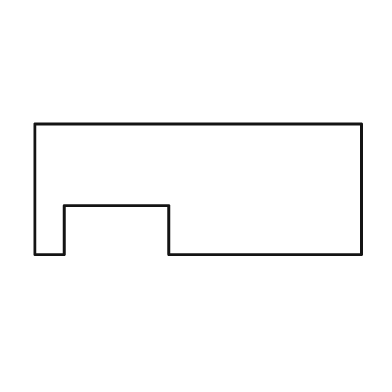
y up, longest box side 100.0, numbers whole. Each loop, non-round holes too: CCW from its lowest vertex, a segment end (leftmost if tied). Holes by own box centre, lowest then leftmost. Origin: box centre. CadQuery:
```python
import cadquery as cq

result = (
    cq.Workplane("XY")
    .moveTo(-50.0, -20.0)
    .lineTo(-41.0, -20.0)
    .lineTo(-41.0, -5.0)
    .lineTo(-9.0, -5.0)
    .lineTo(-9.0, -20.0)
    .lineTo(50.0, -20.0)
    .lineTo(50.0, 20.0)
    .lineTo(-50.0, 20.0)
    .close()
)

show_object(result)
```